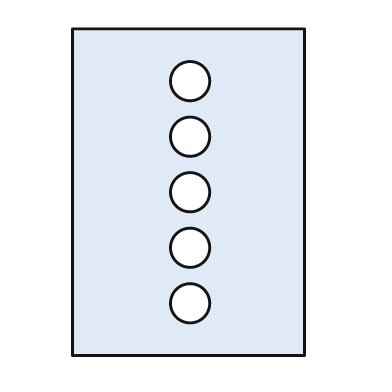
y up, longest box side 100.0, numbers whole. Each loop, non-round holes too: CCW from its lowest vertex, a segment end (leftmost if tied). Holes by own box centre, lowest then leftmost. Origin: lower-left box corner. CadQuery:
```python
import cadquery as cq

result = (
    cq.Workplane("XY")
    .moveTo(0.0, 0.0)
    .lineTo(71.0, 0.0)
    .lineTo(71.0, 100.0)
    .lineTo(0.0, 100.0)
    .close()
    .moveTo(36.0, 16.0)
    .circle(6.0)
    .moveTo(36.0, 33.0)
    .circle(6.0)
    .moveTo(36.0, 50.0)
    .circle(6.0)
    .moveTo(36.0, 67.0)
    .circle(6.0)
    .moveTo(36.0, 84.0)
    .circle(6.0)
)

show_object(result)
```